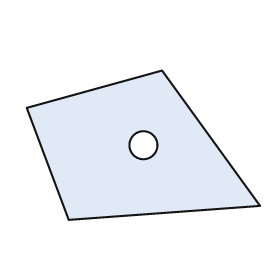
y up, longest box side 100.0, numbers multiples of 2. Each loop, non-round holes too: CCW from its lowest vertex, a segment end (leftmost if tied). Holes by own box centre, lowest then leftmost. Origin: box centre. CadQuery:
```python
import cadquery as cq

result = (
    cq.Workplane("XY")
    .moveTo(-32.0, -32.0)
    .lineTo(50.0, -26.0)
    .lineTo(8.0, 32.0)
    .lineTo(-50.0, 16.0)
    .close()
    .moveTo(0.0, 0.0)
    .circle(6.0)
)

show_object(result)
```